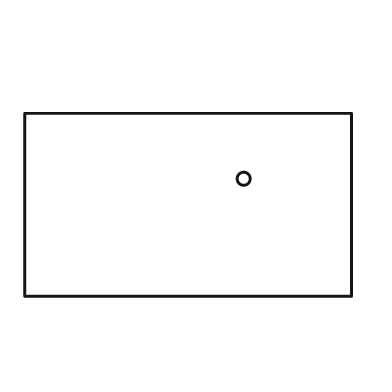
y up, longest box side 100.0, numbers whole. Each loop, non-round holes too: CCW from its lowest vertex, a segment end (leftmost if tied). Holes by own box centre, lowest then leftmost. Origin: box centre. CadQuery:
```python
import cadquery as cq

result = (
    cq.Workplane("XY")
    .moveTo(-50.0, -28.0)
    .lineTo(50.0, -28.0)
    .lineTo(50.0, 28.0)
    .lineTo(-50.0, 28.0)
    .close()
    .moveTo(17.0, 8.0)
    .circle(2.0)
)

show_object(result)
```